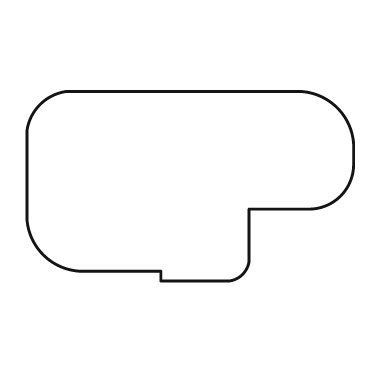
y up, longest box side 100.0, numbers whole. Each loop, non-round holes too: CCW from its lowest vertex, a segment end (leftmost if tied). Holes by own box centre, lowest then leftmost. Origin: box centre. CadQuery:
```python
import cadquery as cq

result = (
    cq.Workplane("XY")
    .moveTo(-9.0, -29.0)
    .lineTo(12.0, -29.0)
    .threePointArc((16.0, -27.0), (18.0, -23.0))
    .lineTo(18.0, -7.0)
    .lineTo(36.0, -7.0)
    .threePointArc((46.0, -3.0), (50.0, 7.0))
    .lineTo(50.0, 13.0)
    .threePointArc((45.0, 24.0), (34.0, 29.0))
    .lineTo(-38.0, 29.0)
    .threePointArc((-46.0, 25.0), (-50.0, 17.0))
    .lineTo(-50.0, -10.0)
    .threePointArc((-45.0, -21.0), (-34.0, -26.0))
    .lineTo(-9.0, -26.0)
    .close()
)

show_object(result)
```